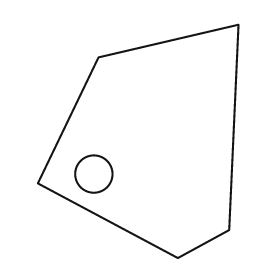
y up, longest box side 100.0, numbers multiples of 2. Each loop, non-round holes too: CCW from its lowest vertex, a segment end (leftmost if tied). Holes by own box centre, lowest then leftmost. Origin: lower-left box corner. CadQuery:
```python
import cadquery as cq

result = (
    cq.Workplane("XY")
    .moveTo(60.0, 0.0)
    .lineTo(82.0, 12.0)
    .lineTo(86.0, 100.0)
    .lineTo(26.0, 86.0)
    .lineTo(0.0, 32.0)
    .close()
    .moveTo(24.0, 36.0)
    .circle(8.0)
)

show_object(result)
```